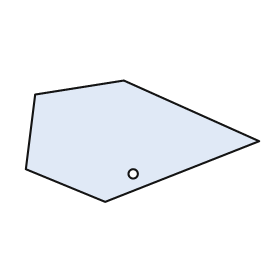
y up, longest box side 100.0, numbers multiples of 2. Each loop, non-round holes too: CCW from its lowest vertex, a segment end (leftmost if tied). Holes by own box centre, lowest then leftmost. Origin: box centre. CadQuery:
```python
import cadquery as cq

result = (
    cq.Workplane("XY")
    .moveTo(-16.0, -26.0)
    .lineTo(50.0, 0.0)
    .lineTo(-8.0, 26.0)
    .lineTo(-46.0, 20.0)
    .lineTo(-50.0, -12.0)
    .close()
    .moveTo(-4.0, -14.0)
    .circle(2.0)
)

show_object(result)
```